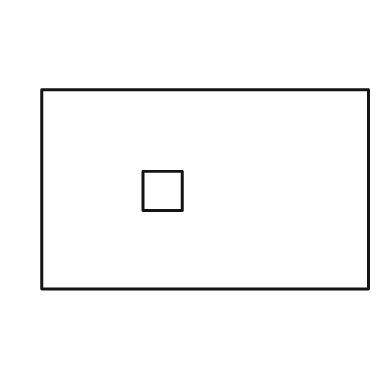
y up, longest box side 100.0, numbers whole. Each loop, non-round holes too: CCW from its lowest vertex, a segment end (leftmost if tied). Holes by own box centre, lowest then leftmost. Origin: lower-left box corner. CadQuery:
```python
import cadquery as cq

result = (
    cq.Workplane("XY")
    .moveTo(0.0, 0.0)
    .lineTo(100.0, 0.0)
    .lineTo(100.0, 61.0)
    .lineTo(0.0, 61.0)
    .close()
    .moveTo(31.0, 24.0)
    .lineTo(43.0, 24.0)
    .lineTo(43.0, 36.0)
    .lineTo(31.0, 36.0)
    .close()
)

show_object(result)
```